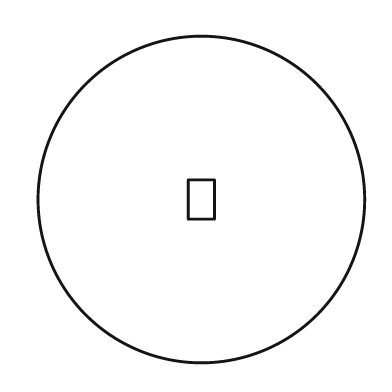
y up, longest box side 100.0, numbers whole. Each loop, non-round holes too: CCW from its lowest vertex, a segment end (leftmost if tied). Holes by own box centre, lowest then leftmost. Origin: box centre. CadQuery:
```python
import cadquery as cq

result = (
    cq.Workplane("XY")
    .moveTo(0.0, 0.0)
    .circle(50.0)
    .moveTo(-4.0, -6.0)
    .lineTo(4.0, -6.0)
    .lineTo(4.0, 6.0)
    .lineTo(-4.0, 6.0)
    .close()
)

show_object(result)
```